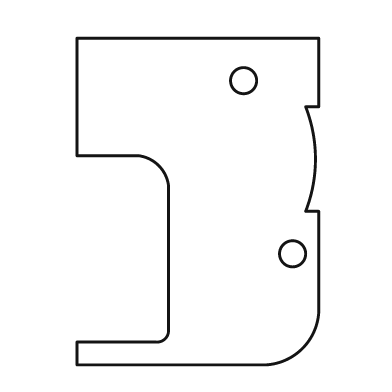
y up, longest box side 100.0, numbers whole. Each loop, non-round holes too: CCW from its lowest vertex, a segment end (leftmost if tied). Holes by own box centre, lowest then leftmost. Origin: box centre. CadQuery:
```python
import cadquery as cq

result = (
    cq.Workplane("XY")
    .moveTo(-37.0, -50.0)
    .lineTo(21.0, -50.0)
    .threePointArc((32.0, -45.0), (37.0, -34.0))
    .lineTo(37.0, -3.0)
    .lineTo(33.0, -3.0)
    .threePointArc((36.0, 13.0), (33.0, 29.0))
    .lineTo(37.0, 29.0)
    .lineTo(37.0, 50.0)
    .lineTo(-37.0, 50.0)
    .lineTo(-37.0, 14.0)
    .lineTo(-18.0, 14.0)
    .threePointArc((-12.0, 11.0), (-9.0, 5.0))
    .lineTo(-9.0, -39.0)
    .threePointArc((-10.0, -42.0), (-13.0, -43.0))
    .lineTo(-37.0, -43.0)
    .close()
    .moveTo(29.0, -16.0)
    .circle(4.0)
    .moveTo(14.0, 37.0)
    .circle(4.0)
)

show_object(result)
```